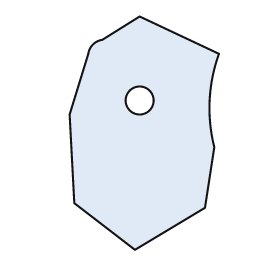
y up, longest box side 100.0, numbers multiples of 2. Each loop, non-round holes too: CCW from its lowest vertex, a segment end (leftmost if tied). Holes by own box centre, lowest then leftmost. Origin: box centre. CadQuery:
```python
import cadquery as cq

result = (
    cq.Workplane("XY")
    .moveTo(-4.0, -50.0)
    .lineTo(26.0, -32.0)
    .lineTo(30.0, -6.0)
    .threePointArc((28.0, 14.0), (32.0, 34.0))
    .lineTo(-2.0, 50.0)
    .lineTo(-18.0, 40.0)
    .threePointArc((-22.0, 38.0), (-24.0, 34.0))
    .lineTo(-32.0, 8.0)
    .lineTo(-30.0, -30.0)
    .close()
    .moveTo(-2.0, 14.0)
    .circle(6.0)
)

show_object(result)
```